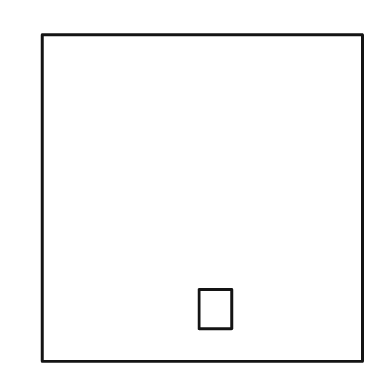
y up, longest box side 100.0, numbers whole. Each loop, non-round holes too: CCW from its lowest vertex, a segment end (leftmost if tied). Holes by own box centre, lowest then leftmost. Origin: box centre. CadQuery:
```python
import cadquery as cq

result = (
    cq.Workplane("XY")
    .moveTo(-49.0, -50.0)
    .lineTo(49.0, -50.0)
    .lineTo(49.0, 50.0)
    .lineTo(-49.0, 50.0)
    .close()
    .moveTo(-1.0, -40.0)
    .lineTo(9.0, -40.0)
    .lineTo(9.0, -28.0)
    .lineTo(-1.0, -28.0)
    .close()
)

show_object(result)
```